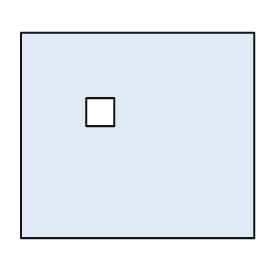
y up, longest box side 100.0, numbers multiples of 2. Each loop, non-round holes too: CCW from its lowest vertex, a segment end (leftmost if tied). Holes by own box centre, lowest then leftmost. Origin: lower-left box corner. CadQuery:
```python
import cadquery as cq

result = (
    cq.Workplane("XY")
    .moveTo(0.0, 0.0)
    .lineTo(100.0, 0.0)
    .lineTo(100.0, 88.0)
    .lineTo(0.0, 88.0)
    .close()
    .moveTo(28.0, 48.0)
    .lineTo(40.0, 48.0)
    .lineTo(40.0, 60.0)
    .lineTo(28.0, 60.0)
    .close()
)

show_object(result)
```